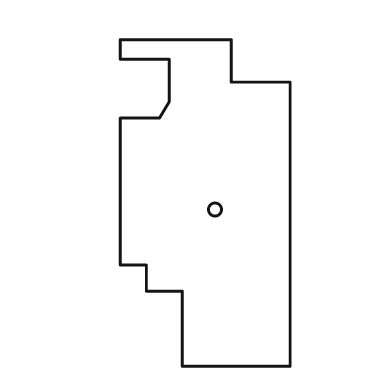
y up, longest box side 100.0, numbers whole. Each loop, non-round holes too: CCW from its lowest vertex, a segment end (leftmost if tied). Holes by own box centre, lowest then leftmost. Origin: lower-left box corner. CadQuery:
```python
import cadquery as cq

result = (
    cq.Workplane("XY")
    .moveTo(19.0, 0.0)
    .lineTo(52.0, 0.0)
    .lineTo(52.0, 87.0)
    .lineTo(34.0, 87.0)
    .lineTo(34.0, 100.0)
    .lineTo(0.0, 100.0)
    .lineTo(0.0, 94.0)
    .lineTo(15.0, 94.0)
    .lineTo(15.0, 81.0)
    .lineTo(12.0, 76.0)
    .lineTo(0.0, 76.0)
    .lineTo(0.0, 31.0)
    .lineTo(8.0, 31.0)
    .lineTo(8.0, 23.0)
    .lineTo(19.0, 23.0)
    .close()
    .moveTo(29.0, 48.0)
    .circle(2.0)
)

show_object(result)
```